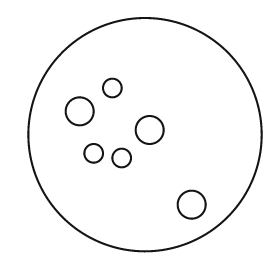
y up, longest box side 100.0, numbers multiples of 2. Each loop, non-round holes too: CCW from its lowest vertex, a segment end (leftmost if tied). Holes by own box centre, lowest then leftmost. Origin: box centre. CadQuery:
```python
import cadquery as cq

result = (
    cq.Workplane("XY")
    .moveTo(0.0, 0.0)
    .circle(50.0)
    .moveTo(20.0, -30.0)
    .circle(6.0)
    .moveTo(-10.0, -10.0)
    .circle(4.0)
    .moveTo(-22.0, -8.0)
    .circle(4.0)
    .moveTo(2.0, 2.0)
    .circle(6.0)
    .moveTo(-28.0, 10.0)
    .circle(6.0)
    .moveTo(-14.0, 20.0)
    .circle(4.0)
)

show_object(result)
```